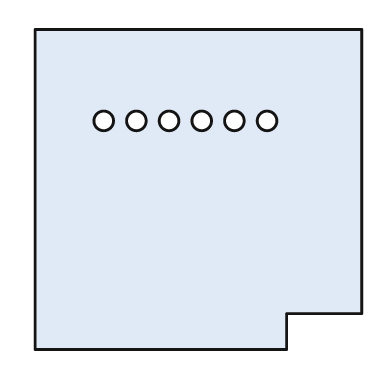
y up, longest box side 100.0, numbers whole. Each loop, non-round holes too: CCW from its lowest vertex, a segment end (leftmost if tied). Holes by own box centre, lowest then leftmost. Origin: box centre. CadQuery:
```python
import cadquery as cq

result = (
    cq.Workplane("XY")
    .moveTo(-50.0, -49.0)
    .lineTo(27.0, -49.0)
    .lineTo(27.0, -38.0)
    .lineTo(50.0, -38.0)
    .lineTo(50.0, 49.0)
    .lineTo(-50.0, 49.0)
    .close()
    .moveTo(-29.0, 21.0)
    .circle(3.0)
    .moveTo(-19.0, 21.0)
    .circle(3.0)
    .moveTo(-9.0, 21.0)
    .circle(3.0)
    .moveTo(1.0, 21.0)
    .circle(3.0)
    .moveTo(11.0, 21.0)
    .circle(3.0)
    .moveTo(21.0, 21.0)
    .circle(3.0)
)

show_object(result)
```